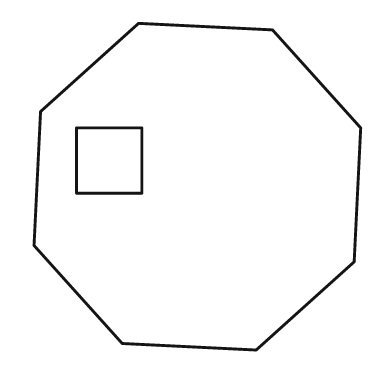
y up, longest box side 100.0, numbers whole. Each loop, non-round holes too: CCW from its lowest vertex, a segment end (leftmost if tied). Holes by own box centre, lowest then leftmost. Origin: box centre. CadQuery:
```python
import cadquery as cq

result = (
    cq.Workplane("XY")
    .moveTo(18.0, -50.0)
    .lineTo(48.0, -23.0)
    .lineTo(50.0, 18.0)
    .lineTo(23.0, 48.0)
    .lineTo(-18.0, 50.0)
    .lineTo(-48.0, 23.0)
    .lineTo(-50.0, -18.0)
    .lineTo(-23.0, -48.0)
    .close()
    .moveTo(-37.0, -2.0)
    .lineTo(-17.0, -2.0)
    .lineTo(-17.0, 18.0)
    .lineTo(-37.0, 18.0)
    .close()
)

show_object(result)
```